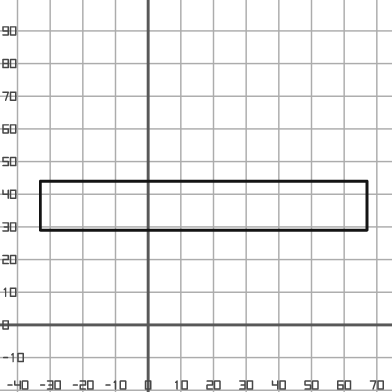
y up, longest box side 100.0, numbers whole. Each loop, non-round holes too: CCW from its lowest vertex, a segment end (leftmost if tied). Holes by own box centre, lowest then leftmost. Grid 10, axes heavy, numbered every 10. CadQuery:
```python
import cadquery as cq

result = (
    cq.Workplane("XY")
    .moveTo(-33.0, 29.0)
    .lineTo(67.0, 29.0)
    .lineTo(67.0, 44.0)
    .lineTo(-33.0, 44.0)
    .close()
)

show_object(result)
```